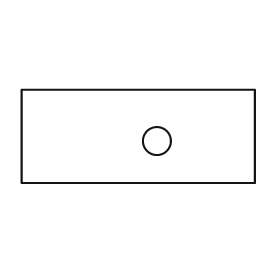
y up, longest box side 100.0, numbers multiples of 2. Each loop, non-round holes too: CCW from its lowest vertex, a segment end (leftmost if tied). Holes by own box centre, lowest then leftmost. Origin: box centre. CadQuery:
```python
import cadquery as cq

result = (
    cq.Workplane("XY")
    .moveTo(-50.0, -20.0)
    .lineTo(50.0, -20.0)
    .lineTo(50.0, 20.0)
    .lineTo(-50.0, 20.0)
    .close()
    .moveTo(8.0, -2.0)
    .circle(6.0)
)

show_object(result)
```